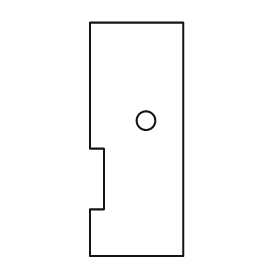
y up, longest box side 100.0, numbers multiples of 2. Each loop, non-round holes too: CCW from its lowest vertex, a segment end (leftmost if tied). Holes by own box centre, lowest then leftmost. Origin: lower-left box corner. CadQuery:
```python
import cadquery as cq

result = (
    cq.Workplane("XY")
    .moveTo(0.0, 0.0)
    .lineTo(40.0, 0.0)
    .lineTo(40.0, 100.0)
    .lineTo(0.0, 100.0)
    .lineTo(0.0, 46.0)
    .lineTo(6.0, 46.0)
    .lineTo(6.0, 20.0)
    .lineTo(0.0, 20.0)
    .close()
    .moveTo(24.0, 58.0)
    .circle(4.0)
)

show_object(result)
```